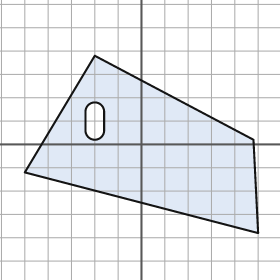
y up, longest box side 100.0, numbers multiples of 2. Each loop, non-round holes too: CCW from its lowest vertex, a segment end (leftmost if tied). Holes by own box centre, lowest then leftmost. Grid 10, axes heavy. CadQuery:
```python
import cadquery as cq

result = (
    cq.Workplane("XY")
    .moveTo(50.0, -38.0)
    .lineTo(48.0, 2.0)
    .lineTo(-20.0, 38.0)
    .lineTo(-50.0, -12.0)
    .close()
    .moveTo(-24.0, 6.0)
    .threePointArc((-20.0, 2.0), (-16.0, 6.0))
    .lineTo(-16.0, 14.0)
    .threePointArc((-20.0, 18.0), (-24.0, 14.0))
    .close()
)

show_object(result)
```